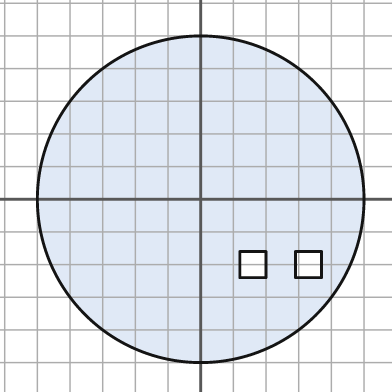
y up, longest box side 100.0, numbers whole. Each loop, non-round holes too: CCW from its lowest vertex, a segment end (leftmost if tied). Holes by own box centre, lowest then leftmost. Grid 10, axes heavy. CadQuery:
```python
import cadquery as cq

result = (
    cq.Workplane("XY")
    .moveTo(0.0, 0.0)
    .circle(50.0)
    .moveTo(12.0, -24.0)
    .lineTo(20.0, -24.0)
    .lineTo(20.0, -16.0)
    .lineTo(12.0, -16.0)
    .close()
    .moveTo(29.0, -24.0)
    .lineTo(37.0, -24.0)
    .lineTo(37.0, -16.0)
    .lineTo(29.0, -16.0)
    .close()
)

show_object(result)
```